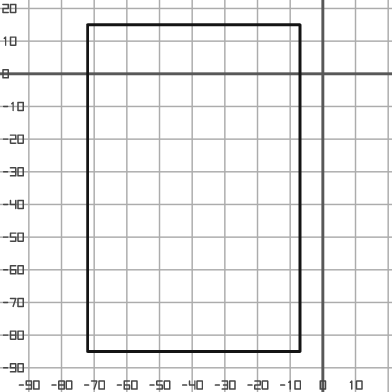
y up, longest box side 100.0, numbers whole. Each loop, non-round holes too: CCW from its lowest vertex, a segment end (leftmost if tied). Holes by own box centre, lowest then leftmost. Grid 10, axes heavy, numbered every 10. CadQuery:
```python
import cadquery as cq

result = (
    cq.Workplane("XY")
    .moveTo(-72.0, -85.0)
    .lineTo(-7.0, -85.0)
    .lineTo(-7.0, 15.0)
    .lineTo(-72.0, 15.0)
    .close()
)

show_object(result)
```